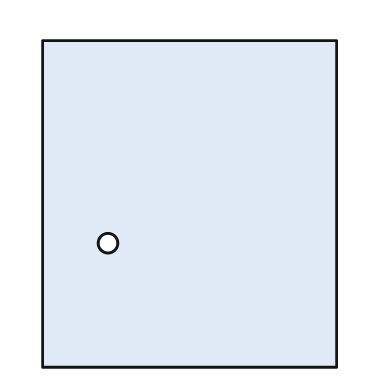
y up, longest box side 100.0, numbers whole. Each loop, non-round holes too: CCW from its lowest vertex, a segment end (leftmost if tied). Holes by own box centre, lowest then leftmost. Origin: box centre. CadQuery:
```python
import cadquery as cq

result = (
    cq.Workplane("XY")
    .moveTo(-45.0, -50.0)
    .lineTo(45.0, -50.0)
    .lineTo(45.0, 50.0)
    .lineTo(-45.0, 50.0)
    .close()
    .moveTo(-25.0, -12.0)
    .circle(3.0)
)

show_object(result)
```